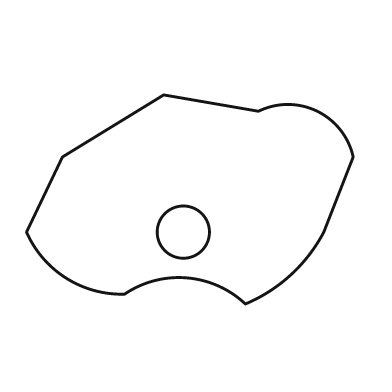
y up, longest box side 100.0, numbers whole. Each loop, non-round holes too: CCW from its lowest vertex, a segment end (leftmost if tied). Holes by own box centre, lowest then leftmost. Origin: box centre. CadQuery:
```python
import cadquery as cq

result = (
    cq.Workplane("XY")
    .moveTo(17.0, -32.0)
    .threePointArc((31.0, -23.0), (41.0, -10.0))
    .lineTo(50.0, 13.0)
    .threePointArc((39.0, 27.0), (21.0, 27.0))
    .lineTo(-8.0, 32.0)
    .lineTo(-39.0, 13.0)
    .lineTo(-50.0, -10.0)
    .threePointArc((-38.0, -24.0), (-20.0, -29.0))
    .threePointArc((-1.0, -24.0), (17.0, -32.0))
    .close()
    .moveTo(-2.0, -10.0)
    .circle(8.0)
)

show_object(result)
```